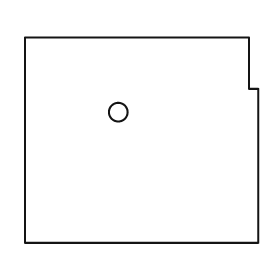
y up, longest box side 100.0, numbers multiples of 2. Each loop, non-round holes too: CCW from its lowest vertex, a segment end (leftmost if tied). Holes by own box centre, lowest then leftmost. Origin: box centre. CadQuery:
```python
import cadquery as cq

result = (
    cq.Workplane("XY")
    .moveTo(-50.0, -44.0)
    .lineTo(50.0, -44.0)
    .lineTo(50.0, 22.0)
    .lineTo(46.0, 22.0)
    .lineTo(46.0, 44.0)
    .lineTo(-50.0, 44.0)
    .close()
    .moveTo(-10.0, 12.0)
    .circle(4.0)
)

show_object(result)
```